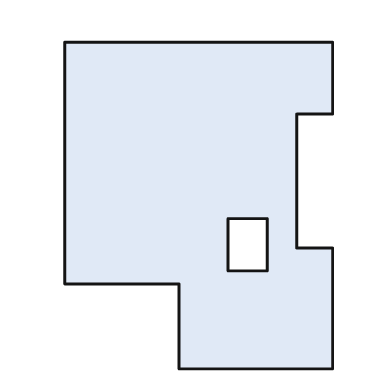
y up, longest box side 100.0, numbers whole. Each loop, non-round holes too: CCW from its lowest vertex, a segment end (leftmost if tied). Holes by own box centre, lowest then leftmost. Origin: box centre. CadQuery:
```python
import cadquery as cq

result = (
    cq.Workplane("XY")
    .moveTo(-6.0, -50.0)
    .lineTo(41.0, -50.0)
    .lineTo(41.0, -13.0)
    .lineTo(30.0, -13.0)
    .lineTo(30.0, 28.0)
    .lineTo(41.0, 28.0)
    .lineTo(41.0, 50.0)
    .lineTo(-41.0, 50.0)
    .lineTo(-41.0, -24.0)
    .lineTo(-6.0, -24.0)
    .close()
    .moveTo(9.0, -20.0)
    .lineTo(21.0, -20.0)
    .lineTo(21.0, -4.0)
    .lineTo(9.0, -4.0)
    .close()
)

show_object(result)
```